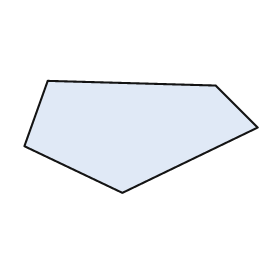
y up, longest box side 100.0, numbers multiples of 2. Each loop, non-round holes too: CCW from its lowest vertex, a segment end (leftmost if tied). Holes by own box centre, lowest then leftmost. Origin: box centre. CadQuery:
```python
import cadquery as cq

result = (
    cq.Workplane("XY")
    .moveTo(-8.0, -24.0)
    .lineTo(50.0, 4.0)
    .lineTo(32.0, 22.0)
    .lineTo(-40.0, 24.0)
    .lineTo(-50.0, -4.0)
    .close()
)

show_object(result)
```